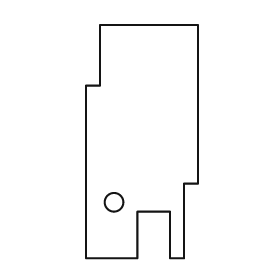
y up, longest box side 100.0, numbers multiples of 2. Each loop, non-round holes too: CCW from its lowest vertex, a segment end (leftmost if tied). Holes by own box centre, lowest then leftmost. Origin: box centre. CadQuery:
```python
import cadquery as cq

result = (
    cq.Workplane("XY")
    .moveTo(-24.0, -50.0)
    .lineTo(-2.0, -50.0)
    .lineTo(-2.0, -30.0)
    .lineTo(12.0, -30.0)
    .lineTo(12.0, -50.0)
    .lineTo(18.0, -50.0)
    .lineTo(18.0, -18.0)
    .lineTo(24.0, -18.0)
    .lineTo(24.0, 50.0)
    .lineTo(-18.0, 50.0)
    .lineTo(-18.0, 24.0)
    .lineTo(-24.0, 24.0)
    .close()
    .moveTo(-12.0, -26.0)
    .circle(4.0)
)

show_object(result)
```